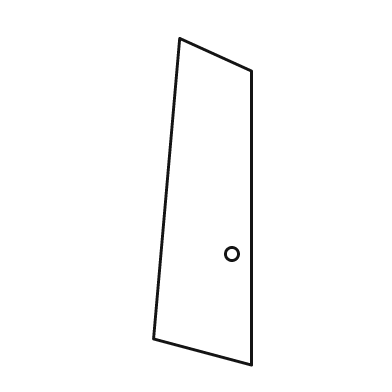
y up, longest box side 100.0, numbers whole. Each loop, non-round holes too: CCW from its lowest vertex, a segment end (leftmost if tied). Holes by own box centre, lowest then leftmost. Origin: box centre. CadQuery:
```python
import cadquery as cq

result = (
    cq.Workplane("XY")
    .moveTo(15.0, -50.0)
    .lineTo(15.0, 40.0)
    .lineTo(-7.0, 50.0)
    .lineTo(-15.0, -42.0)
    .close()
    .moveTo(9.0, -16.0)
    .circle(2.0)
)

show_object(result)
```